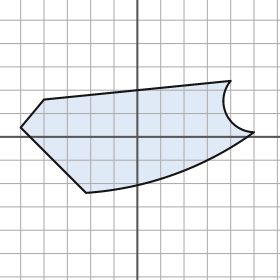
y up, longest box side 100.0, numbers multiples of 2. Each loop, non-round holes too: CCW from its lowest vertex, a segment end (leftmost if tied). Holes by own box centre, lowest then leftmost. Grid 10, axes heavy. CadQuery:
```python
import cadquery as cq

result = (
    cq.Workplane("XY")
    .moveTo(-22.0, -24.0)
    .threePointArc((16.0, -16.0), (50.0, 2.0))
    .threePointArc((38.0, 10.0), (40.0, 24.0))
    .lineTo(-40.0, 16.0)
    .lineTo(-50.0, 4.0)
    .close()
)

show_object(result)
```